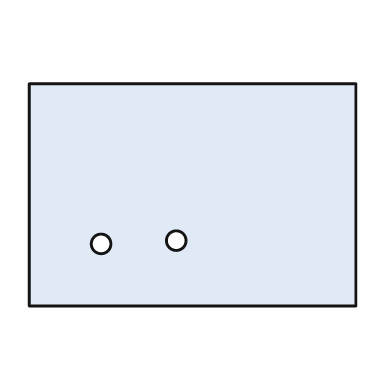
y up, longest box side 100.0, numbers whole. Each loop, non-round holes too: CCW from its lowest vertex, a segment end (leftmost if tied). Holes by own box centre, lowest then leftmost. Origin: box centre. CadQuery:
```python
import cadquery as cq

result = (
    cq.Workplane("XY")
    .moveTo(-50.0, -34.0)
    .lineTo(50.0, -34.0)
    .lineTo(50.0, 34.0)
    .lineTo(-50.0, 34.0)
    .close()
    .moveTo(-28.0, -15.0)
    .circle(3.0)
    .moveTo(-5.0, -14.0)
    .circle(3.0)
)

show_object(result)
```